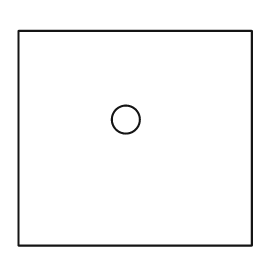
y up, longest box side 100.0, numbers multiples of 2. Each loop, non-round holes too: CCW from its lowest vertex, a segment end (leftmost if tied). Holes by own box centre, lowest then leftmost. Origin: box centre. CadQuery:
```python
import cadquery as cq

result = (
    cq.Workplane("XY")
    .moveTo(-50.0, -46.0)
    .lineTo(50.0, -46.0)
    .lineTo(50.0, 46.0)
    .lineTo(-50.0, 46.0)
    .close()
    .moveTo(-4.0, 8.0)
    .circle(6.0)
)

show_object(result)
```